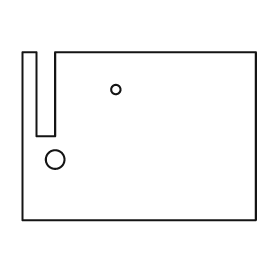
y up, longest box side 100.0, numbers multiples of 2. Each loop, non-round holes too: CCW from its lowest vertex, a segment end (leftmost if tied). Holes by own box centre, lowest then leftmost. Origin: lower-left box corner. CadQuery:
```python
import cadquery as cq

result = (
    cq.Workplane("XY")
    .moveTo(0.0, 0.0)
    .lineTo(100.0, 0.0)
    .lineTo(100.0, 72.0)
    .lineTo(14.0, 72.0)
    .lineTo(14.0, 36.0)
    .lineTo(6.0, 36.0)
    .lineTo(6.0, 72.0)
    .lineTo(0.0, 72.0)
    .close()
    .moveTo(14.0, 26.0)
    .circle(4.0)
    .moveTo(40.0, 56.0)
    .circle(2.0)
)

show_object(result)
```